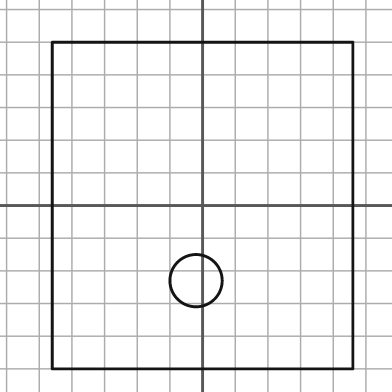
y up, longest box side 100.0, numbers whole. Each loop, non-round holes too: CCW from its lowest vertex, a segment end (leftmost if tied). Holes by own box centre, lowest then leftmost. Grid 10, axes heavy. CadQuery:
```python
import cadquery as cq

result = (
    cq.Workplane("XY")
    .moveTo(-46.0, -50.0)
    .lineTo(46.0, -50.0)
    .lineTo(46.0, 50.0)
    .lineTo(-46.0, 50.0)
    .close()
    .moveTo(-2.0, -23.0)
    .circle(8.0)
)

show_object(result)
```